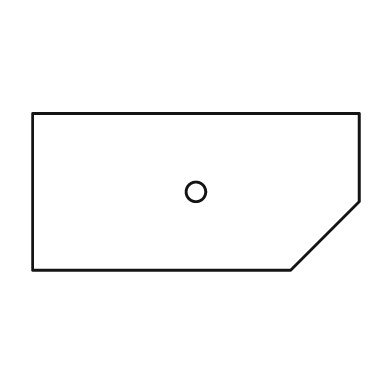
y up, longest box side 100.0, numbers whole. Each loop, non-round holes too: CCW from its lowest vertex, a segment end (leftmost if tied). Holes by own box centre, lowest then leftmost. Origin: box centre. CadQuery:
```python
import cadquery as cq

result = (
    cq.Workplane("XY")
    .moveTo(-50.0, -24.0)
    .lineTo(29.0, -24.0)
    .lineTo(50.0, -3.0)
    .lineTo(50.0, 24.0)
    .lineTo(-50.0, 24.0)
    .close()
    .moveTo(0.0, 0.0)
    .circle(3.0)
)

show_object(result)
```